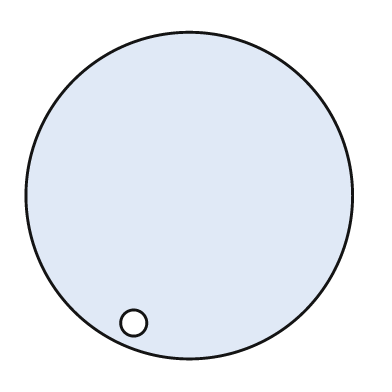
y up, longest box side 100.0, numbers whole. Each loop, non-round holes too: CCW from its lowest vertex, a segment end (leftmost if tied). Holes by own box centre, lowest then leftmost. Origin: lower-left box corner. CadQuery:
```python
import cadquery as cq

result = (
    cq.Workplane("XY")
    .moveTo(50.0, 50.0)
    .circle(50.0)
    .moveTo(33.0, 11.0)
    .circle(4.0)
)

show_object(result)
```